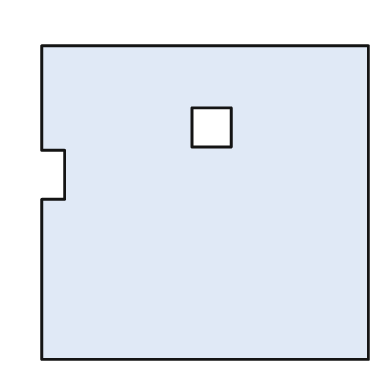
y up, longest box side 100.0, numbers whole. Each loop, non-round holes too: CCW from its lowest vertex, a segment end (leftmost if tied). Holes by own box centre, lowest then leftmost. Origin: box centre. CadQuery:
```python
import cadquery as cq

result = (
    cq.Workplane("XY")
    .moveTo(-50.0, -48.0)
    .lineTo(50.0, -48.0)
    .lineTo(50.0, 48.0)
    .lineTo(-50.0, 48.0)
    .lineTo(-50.0, 16.0)
    .lineTo(-43.0, 16.0)
    .lineTo(-43.0, 1.0)
    .lineTo(-50.0, 1.0)
    .close()
    .moveTo(-4.0, 17.0)
    .lineTo(8.0, 17.0)
    .lineTo(8.0, 29.0)
    .lineTo(-4.0, 29.0)
    .close()
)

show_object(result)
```